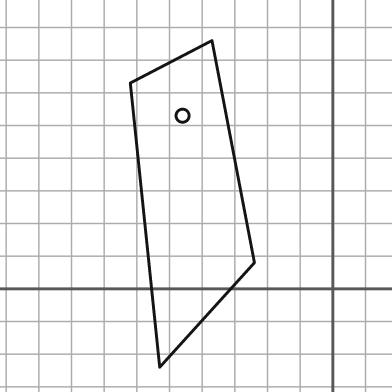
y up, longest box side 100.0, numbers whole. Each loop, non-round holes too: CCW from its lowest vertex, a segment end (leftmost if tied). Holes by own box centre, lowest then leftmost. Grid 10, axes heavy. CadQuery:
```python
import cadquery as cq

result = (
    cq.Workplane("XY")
    .moveTo(-53.0, -24.0)
    .lineTo(-24.0, 8.0)
    .lineTo(-37.0, 76.0)
    .lineTo(-62.0, 63.0)
    .close()
    .moveTo(-46.0, 53.0)
    .circle(2.0)
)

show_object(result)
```